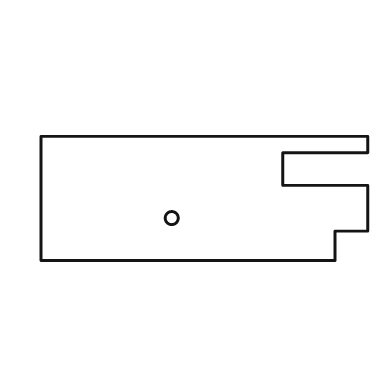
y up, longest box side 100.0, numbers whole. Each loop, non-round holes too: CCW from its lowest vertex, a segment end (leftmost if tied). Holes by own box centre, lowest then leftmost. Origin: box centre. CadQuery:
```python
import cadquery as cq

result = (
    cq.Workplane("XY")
    .moveTo(-50.0, -19.0)
    .lineTo(40.0, -19.0)
    .lineTo(40.0, -10.0)
    .lineTo(50.0, -10.0)
    .lineTo(50.0, 4.0)
    .lineTo(24.0, 4.0)
    .lineTo(24.0, 14.0)
    .lineTo(50.0, 14.0)
    .lineTo(50.0, 19.0)
    .lineTo(-50.0, 19.0)
    .close()
    .moveTo(-10.0, -6.0)
    .circle(2.0)
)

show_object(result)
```